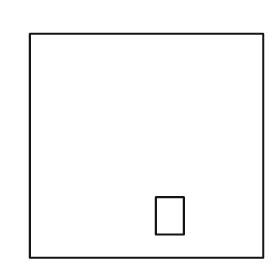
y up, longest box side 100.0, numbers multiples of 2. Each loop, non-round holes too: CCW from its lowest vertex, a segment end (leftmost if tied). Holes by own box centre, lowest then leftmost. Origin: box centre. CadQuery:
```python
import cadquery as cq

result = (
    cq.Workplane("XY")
    .moveTo(-50.0, -48.0)
    .lineTo(50.0, -48.0)
    .lineTo(50.0, 48.0)
    .lineTo(-50.0, 48.0)
    .close()
    .moveTo(4.0, -38.0)
    .lineTo(16.0, -38.0)
    .lineTo(16.0, -22.0)
    .lineTo(4.0, -22.0)
    .close()
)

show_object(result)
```